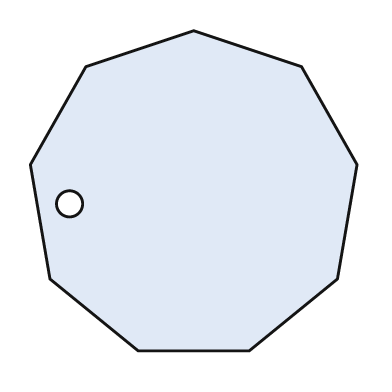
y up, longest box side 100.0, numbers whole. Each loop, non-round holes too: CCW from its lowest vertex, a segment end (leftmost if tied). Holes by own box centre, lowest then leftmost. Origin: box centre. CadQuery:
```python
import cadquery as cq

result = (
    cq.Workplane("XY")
    .moveTo(-17.0, -49.0)
    .lineTo(17.0, -49.0)
    .lineTo(44.0, -27.0)
    .lineTo(50.0, 8.0)
    .lineTo(33.0, 38.0)
    .lineTo(0.0, 49.0)
    .lineTo(-33.0, 38.0)
    .lineTo(-50.0, 8.0)
    .lineTo(-44.0, -27.0)
    .close()
    .moveTo(-38.0, -4.0)
    .circle(4.0)
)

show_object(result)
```